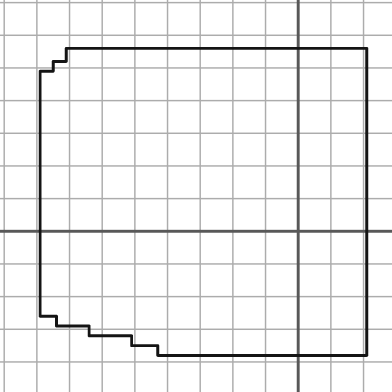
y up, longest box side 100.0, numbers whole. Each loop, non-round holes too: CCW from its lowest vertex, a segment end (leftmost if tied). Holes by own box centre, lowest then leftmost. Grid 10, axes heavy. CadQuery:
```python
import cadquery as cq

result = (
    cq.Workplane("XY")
    .moveTo(-43.0, -38.0)
    .lineTo(21.0, -38.0)
    .lineTo(21.0, 56.0)
    .lineTo(-71.0, 56.0)
    .lineTo(-71.0, 52.0)
    .lineTo(-75.0, 52.0)
    .lineTo(-75.0, 49.0)
    .lineTo(-79.0, 49.0)
    .lineTo(-79.0, -26.0)
    .lineTo(-74.0, -26.0)
    .lineTo(-74.0, -29.0)
    .lineTo(-64.0, -29.0)
    .lineTo(-64.0, -32.0)
    .lineTo(-51.0, -32.0)
    .lineTo(-51.0, -35.0)
    .lineTo(-43.0, -35.0)
    .close()
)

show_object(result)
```